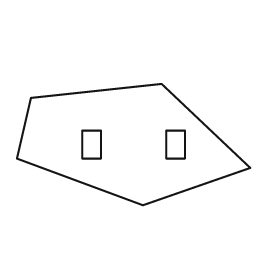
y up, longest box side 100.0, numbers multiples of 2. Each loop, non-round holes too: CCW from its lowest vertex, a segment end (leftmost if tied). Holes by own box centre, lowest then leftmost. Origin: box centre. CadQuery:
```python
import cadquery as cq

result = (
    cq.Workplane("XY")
    .moveTo(4.0, -26.0)
    .lineTo(50.0, -10.0)
    .lineTo(12.0, 26.0)
    .lineTo(-44.0, 20.0)
    .lineTo(-50.0, -6.0)
    .close()
    .moveTo(-22.0, -6.0)
    .lineTo(-14.0, -6.0)
    .lineTo(-14.0, 6.0)
    .lineTo(-22.0, 6.0)
    .close()
    .moveTo(14.0, -6.0)
    .lineTo(22.0, -6.0)
    .lineTo(22.0, 6.0)
    .lineTo(14.0, 6.0)
    .close()
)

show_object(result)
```